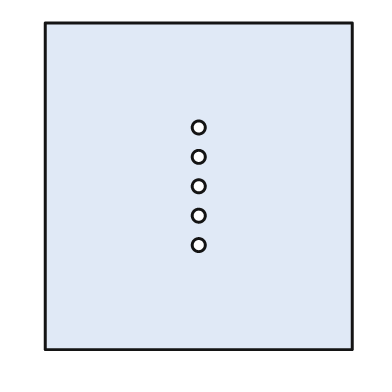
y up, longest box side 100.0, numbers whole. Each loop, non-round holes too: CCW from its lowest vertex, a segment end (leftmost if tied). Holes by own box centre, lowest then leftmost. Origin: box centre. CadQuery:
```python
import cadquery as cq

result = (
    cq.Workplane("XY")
    .moveTo(-47.0, -50.0)
    .lineTo(47.0, -50.0)
    .lineTo(47.0, 50.0)
    .lineTo(-47.0, 50.0)
    .close()
    .moveTo(0.0, -18.0)
    .circle(2.0)
    .moveTo(0.0, -9.0)
    .circle(2.0)
    .moveTo(0.0, 0.0)
    .circle(2.0)
    .moveTo(0.0, 9.0)
    .circle(2.0)
    .moveTo(0.0, 18.0)
    .circle(2.0)
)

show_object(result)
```